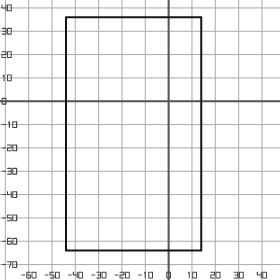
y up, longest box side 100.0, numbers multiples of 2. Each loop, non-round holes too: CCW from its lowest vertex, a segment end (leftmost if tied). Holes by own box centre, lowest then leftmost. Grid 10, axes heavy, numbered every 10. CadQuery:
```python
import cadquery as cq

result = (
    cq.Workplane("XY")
    .moveTo(-44.0, -64.0)
    .lineTo(14.0, -64.0)
    .lineTo(14.0, 36.0)
    .lineTo(-44.0, 36.0)
    .close()
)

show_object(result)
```